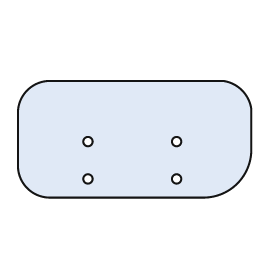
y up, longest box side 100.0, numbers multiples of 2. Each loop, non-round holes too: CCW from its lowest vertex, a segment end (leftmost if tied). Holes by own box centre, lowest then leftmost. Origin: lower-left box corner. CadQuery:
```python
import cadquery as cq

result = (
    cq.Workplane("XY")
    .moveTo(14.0, 0.0)
    .lineTo(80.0, 0.0)
    .threePointArc((94.0, 6.0), (100.0, 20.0))
    .lineTo(100.0, 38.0)
    .threePointArc((96.0, 46.0), (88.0, 50.0))
    .lineTo(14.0, 50.0)
    .threePointArc((4.0, 46.0), (0.0, 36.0))
    .lineTo(0.0, 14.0)
    .threePointArc((4.0, 4.0), (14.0, 0.0))
    .close()
    .moveTo(30.0, 8.0)
    .circle(2.0)
    .moveTo(68.0, 8.0)
    .circle(2.0)
    .moveTo(30.0, 24.0)
    .circle(2.0)
    .moveTo(68.0, 24.0)
    .circle(2.0)
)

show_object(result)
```